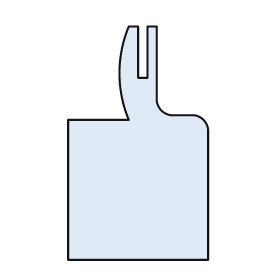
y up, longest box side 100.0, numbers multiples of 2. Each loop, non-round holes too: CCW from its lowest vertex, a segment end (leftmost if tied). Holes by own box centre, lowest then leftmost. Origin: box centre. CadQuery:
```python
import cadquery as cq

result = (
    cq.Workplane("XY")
    .moveTo(-30.0, -50.0)
    .lineTo(30.0, -50.0)
    .lineTo(30.0, 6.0)
    .threePointArc((28.0, 10.0), (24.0, 12.0))
    .lineTo(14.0, 12.0)
    .threePointArc((10.0, 14.0), (8.0, 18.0))
    .lineTo(8.0, 50.0)
    .lineTo(4.0, 50.0)
    .lineTo(4.0, 28.0)
    .lineTo(0.0, 28.0)
    .lineTo(0.0, 50.0)
    .lineTo(-4.0, 50.0)
    .threePointArc((-8.0, 30.0), (-4.0, 10.0))
    .lineTo(-30.0, 10.0)
    .close()
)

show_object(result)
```